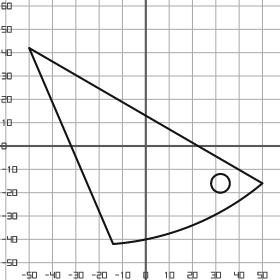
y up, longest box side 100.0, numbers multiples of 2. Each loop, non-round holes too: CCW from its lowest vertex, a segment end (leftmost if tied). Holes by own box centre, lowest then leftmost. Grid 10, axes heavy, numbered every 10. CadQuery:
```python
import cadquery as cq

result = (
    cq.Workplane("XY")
    .moveTo(-14.0, -42.0)
    .threePointArc((20.0, -34.0), (50.0, -16.0))
    .lineTo(-50.0, 42.0)
    .close()
    .moveTo(32.0, -16.0)
    .circle(4.0)
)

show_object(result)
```